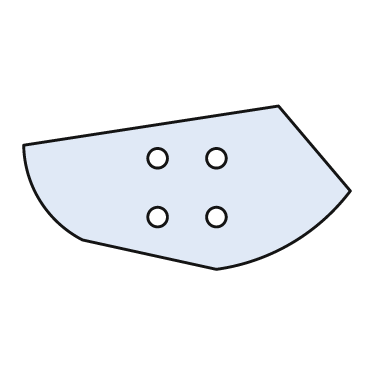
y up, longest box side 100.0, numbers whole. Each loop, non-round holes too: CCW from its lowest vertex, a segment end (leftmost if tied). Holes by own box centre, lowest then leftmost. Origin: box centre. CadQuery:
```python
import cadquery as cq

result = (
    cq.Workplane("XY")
    .moveTo(9.0, -25.0)
    .threePointArc((32.0, -17.0), (50.0, -1.0))
    .lineTo(28.0, 25.0)
    .lineTo(-50.0, 13.0)
    .threePointArc((-45.0, -4.0), (-32.0, -16.0))
    .close()
    .moveTo(-9.0, -9.0)
    .circle(3.0)
    .moveTo(9.0, -9.0)
    .circle(3.0)
    .moveTo(-9.0, 9.0)
    .circle(3.0)
    .moveTo(9.0, 9.0)
    .circle(3.0)
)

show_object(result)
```